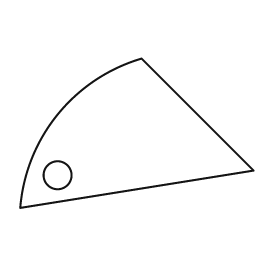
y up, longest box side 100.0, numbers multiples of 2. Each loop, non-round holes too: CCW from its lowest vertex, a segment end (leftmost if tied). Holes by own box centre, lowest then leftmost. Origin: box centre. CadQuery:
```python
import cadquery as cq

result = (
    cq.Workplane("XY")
    .moveTo(-50.0, -32.0)
    .lineTo(50.0, -16.0)
    .lineTo(2.0, 32.0)
    .threePointArc((-34.0, 8.0), (-50.0, -32.0))
    .close()
    .moveTo(-34.0, -18.0)
    .circle(6.0)
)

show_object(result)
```